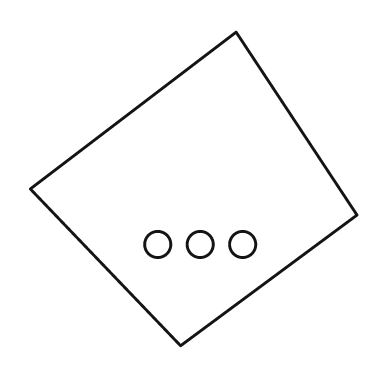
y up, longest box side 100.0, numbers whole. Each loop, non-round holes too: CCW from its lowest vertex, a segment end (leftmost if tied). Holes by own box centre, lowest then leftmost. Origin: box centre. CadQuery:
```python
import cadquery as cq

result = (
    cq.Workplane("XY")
    .moveTo(-4.0, -48.0)
    .lineTo(50.0, -8.0)
    .lineTo(13.0, 48.0)
    .lineTo(-50.0, 0.0)
    .close()
    .moveTo(-11.0, -17.0)
    .circle(4.0)
    .moveTo(2.0, -17.0)
    .circle(4.0)
    .moveTo(15.0, -17.0)
    .circle(4.0)
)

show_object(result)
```